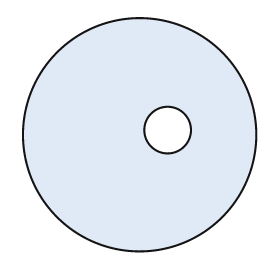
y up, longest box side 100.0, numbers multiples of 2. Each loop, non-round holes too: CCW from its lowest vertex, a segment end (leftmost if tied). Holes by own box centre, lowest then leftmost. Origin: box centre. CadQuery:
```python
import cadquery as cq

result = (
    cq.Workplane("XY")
    .moveTo(0.0, 0.0)
    .circle(50.0)
    .moveTo(12.0, 2.0)
    .circle(10.0)
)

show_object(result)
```